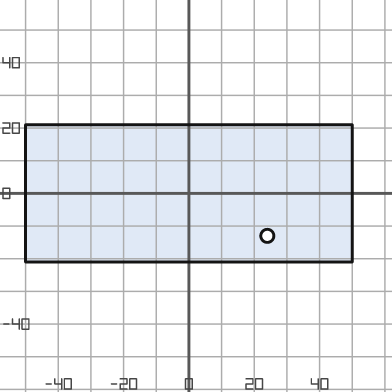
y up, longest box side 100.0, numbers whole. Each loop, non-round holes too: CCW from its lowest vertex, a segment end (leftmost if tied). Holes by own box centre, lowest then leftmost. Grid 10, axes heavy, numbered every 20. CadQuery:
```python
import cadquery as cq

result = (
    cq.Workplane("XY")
    .moveTo(-50.0, -21.0)
    .lineTo(50.0, -21.0)
    .lineTo(50.0, 21.0)
    .lineTo(-50.0, 21.0)
    .close()
    .moveTo(24.0, -13.0)
    .circle(2.0)
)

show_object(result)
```